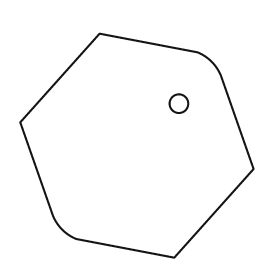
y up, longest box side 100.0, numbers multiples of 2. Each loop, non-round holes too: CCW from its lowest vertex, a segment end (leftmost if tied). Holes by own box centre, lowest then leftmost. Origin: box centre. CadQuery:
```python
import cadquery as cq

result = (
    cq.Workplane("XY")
    .moveTo(16.0, -48.0)
    .lineTo(50.0, -10.0)
    .lineTo(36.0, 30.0)
    .threePointArc((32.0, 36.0), (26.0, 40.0))
    .lineTo(-16.0, 48.0)
    .lineTo(-50.0, 10.0)
    .lineTo(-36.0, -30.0)
    .threePointArc((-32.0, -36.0), (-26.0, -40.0))
    .close()
    .moveTo(18.0, 18.0)
    .circle(4.0)
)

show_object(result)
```